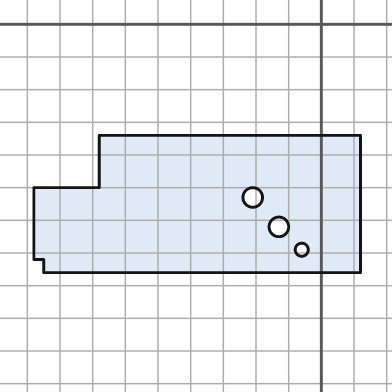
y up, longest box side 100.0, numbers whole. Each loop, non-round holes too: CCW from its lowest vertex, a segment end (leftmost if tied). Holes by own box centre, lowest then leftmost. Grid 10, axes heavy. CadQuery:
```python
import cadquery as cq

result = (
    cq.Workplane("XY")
    .moveTo(-85.0, -76.0)
    .lineTo(12.0, -76.0)
    .lineTo(12.0, -34.0)
    .lineTo(-68.0, -34.0)
    .lineTo(-68.0, -50.0)
    .lineTo(-88.0, -50.0)
    .lineTo(-88.0, -72.0)
    .lineTo(-85.0, -72.0)
    .close()
    .moveTo(-6.0, -69.0)
    .circle(2.0)
    .moveTo(-13.0, -62.0)
    .circle(3.0)
    .moveTo(-21.0, -53.0)
    .circle(3.0)
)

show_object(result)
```